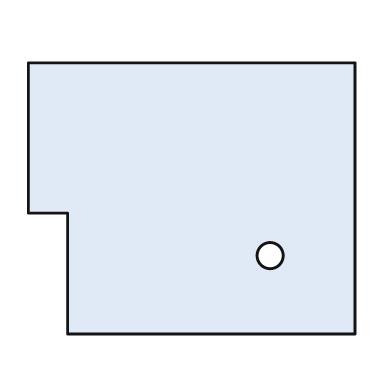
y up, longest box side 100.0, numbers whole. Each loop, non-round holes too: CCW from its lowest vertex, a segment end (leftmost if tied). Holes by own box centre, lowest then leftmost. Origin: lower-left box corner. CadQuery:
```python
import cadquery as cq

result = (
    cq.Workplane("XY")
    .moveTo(12.0, 0.0)
    .lineTo(100.0, 0.0)
    .lineTo(100.0, 83.0)
    .lineTo(0.0, 83.0)
    .lineTo(0.0, 37.0)
    .lineTo(12.0, 37.0)
    .close()
    .moveTo(74.0, 24.0)
    .circle(4.0)
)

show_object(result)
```